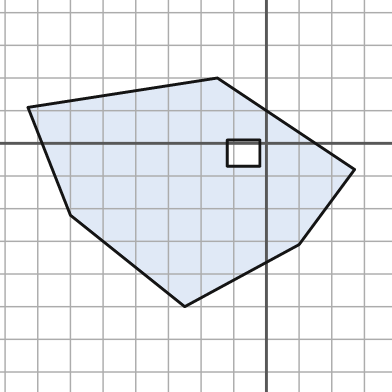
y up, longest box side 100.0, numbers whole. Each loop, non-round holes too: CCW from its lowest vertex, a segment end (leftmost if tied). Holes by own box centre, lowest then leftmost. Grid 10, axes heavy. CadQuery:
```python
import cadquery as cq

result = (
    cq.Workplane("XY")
    .moveTo(-25.0, -50.0)
    .lineTo(10.0, -31.0)
    .lineTo(27.0, -8.0)
    .lineTo(-15.0, 20.0)
    .lineTo(-73.0, 11.0)
    .lineTo(-60.0, -22.0)
    .close()
    .moveTo(-12.0, -7.0)
    .lineTo(-2.0, -7.0)
    .lineTo(-2.0, 1.0)
    .lineTo(-12.0, 1.0)
    .close()
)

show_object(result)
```